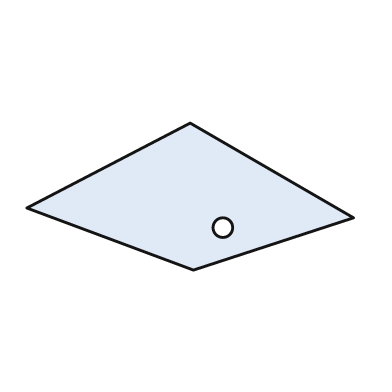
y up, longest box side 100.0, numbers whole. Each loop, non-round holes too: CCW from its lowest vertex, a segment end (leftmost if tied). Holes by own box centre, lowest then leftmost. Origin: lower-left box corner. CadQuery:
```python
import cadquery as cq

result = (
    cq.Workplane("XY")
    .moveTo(51.0, 0.0)
    .lineTo(100.0, 16.0)
    .lineTo(50.0, 45.0)
    .lineTo(0.0, 19.0)
    .close()
    .moveTo(60.0, 13.0)
    .circle(3.0)
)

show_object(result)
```